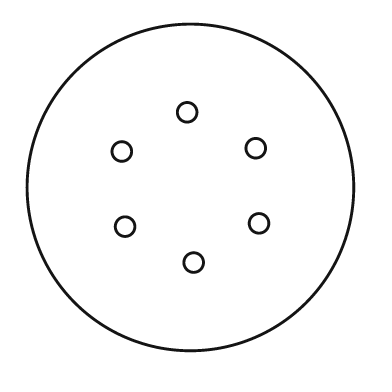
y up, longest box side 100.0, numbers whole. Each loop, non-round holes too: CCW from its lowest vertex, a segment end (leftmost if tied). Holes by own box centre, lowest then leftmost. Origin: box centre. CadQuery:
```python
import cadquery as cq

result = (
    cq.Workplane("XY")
    .moveTo(0.0, 0.0)
    .circle(50.0)
    .moveTo(1.0, -23.0)
    .circle(3.0)
    .moveTo(-20.0, -12.0)
    .circle(3.0)
    .moveTo(21.0, -11.0)
    .circle(3.0)
    .moveTo(-21.0, 11.0)
    .circle(3.0)
    .moveTo(20.0, 12.0)
    .circle(3.0)
    .moveTo(-1.0, 23.0)
    .circle(3.0)
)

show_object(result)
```